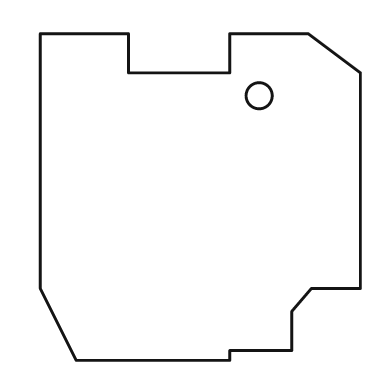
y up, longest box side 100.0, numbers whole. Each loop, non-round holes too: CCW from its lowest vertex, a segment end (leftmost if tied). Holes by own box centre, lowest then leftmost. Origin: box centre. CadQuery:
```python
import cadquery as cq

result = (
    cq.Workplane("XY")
    .moveTo(-38.0, -50.0)
    .lineTo(9.0, -50.0)
    .lineTo(9.0, -47.0)
    .lineTo(28.0, -47.0)
    .lineTo(28.0, -35.0)
    .lineTo(34.0, -28.0)
    .lineTo(49.0, -28.0)
    .lineTo(49.0, 38.0)
    .lineTo(33.0, 50.0)
    .lineTo(9.0, 50.0)
    .lineTo(9.0, 38.0)
    .lineTo(-22.0, 38.0)
    .lineTo(-22.0, 50.0)
    .lineTo(-49.0, 50.0)
    .lineTo(-49.0, -28.0)
    .close()
    .moveTo(18.0, 31.0)
    .circle(4.0)
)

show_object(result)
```